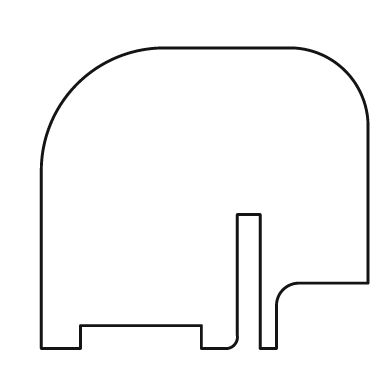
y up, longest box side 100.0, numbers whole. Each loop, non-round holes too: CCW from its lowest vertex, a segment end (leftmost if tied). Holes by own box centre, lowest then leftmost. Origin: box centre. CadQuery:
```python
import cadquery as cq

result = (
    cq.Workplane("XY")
    .moveTo(-50.0, -46.0)
    .lineTo(-38.0, -46.0)
    .lineTo(-38.0, -39.0)
    .lineTo(-1.0, -39.0)
    .lineTo(-1.0, -46.0)
    .lineTo(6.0, -46.0)
    .threePointArc((9.0, -45.0), (10.0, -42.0))
    .lineTo(10.0, -5.0)
    .lineTo(17.0, -5.0)
    .lineTo(17.0, -46.0)
    .lineTo(22.0, -46.0)
    .lineTo(22.0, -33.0)
    .threePointArc((24.0, -28.0), (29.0, -26.0))
    .lineTo(50.0, -26.0)
    .lineTo(50.0, 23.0)
    .threePointArc((43.0, 39.0), (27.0, 46.0))
    .lineTo(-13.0, 46.0)
    .threePointArc((-39.0, 35.0), (-50.0, 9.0))
    .close()
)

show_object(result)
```